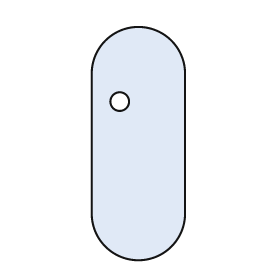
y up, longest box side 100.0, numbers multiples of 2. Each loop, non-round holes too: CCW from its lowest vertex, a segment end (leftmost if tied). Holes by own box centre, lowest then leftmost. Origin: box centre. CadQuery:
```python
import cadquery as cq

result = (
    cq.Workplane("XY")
    .moveTo(-20.0, -30.0)
    .threePointArc((0.0, -50.0), (20.0, -30.0))
    .lineTo(20.0, 30.0)
    .threePointArc((0.0, 50.0), (-20.0, 30.0))
    .close()
    .moveTo(-8.0, 18.0)
    .circle(4.0)
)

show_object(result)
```